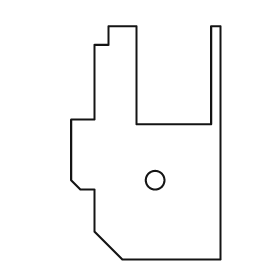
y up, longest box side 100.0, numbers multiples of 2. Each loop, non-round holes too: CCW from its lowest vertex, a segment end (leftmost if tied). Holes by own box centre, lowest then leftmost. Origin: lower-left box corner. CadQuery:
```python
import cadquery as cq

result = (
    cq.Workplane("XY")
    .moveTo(22.0, 0.0)
    .lineTo(64.0, 0.0)
    .lineTo(64.0, 100.0)
    .lineTo(60.0, 100.0)
    .lineTo(60.0, 58.0)
    .lineTo(28.0, 58.0)
    .lineTo(28.0, 100.0)
    .lineTo(16.0, 100.0)
    .lineTo(16.0, 92.0)
    .lineTo(10.0, 92.0)
    .lineTo(10.0, 60.0)
    .lineTo(0.0, 60.0)
    .lineTo(0.0, 34.0)
    .lineTo(4.0, 30.0)
    .lineTo(10.0, 30.0)
    .lineTo(10.0, 12.0)
    .close()
    .moveTo(36.0, 34.0)
    .circle(4.0)
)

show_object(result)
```